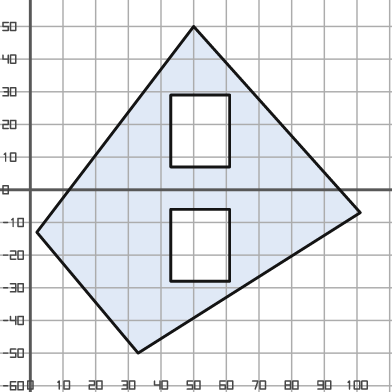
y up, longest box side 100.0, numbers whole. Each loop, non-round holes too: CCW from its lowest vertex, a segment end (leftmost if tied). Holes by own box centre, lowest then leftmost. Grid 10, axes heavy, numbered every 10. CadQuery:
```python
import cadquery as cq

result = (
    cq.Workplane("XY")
    .moveTo(33.0, -50.0)
    .lineTo(101.0, -7.0)
    .lineTo(50.0, 50.0)
    .lineTo(2.0, -13.0)
    .close()
    .moveTo(43.0, -28.0)
    .lineTo(61.0, -28.0)
    .lineTo(61.0, -6.0)
    .lineTo(43.0, -6.0)
    .close()
    .moveTo(43.0, 7.0)
    .lineTo(61.0, 7.0)
    .lineTo(61.0, 29.0)
    .lineTo(43.0, 29.0)
    .close()
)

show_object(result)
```